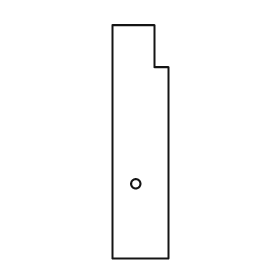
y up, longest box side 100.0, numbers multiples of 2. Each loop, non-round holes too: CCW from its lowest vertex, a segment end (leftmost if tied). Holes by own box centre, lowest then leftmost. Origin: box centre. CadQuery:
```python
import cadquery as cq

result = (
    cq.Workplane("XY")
    .moveTo(-12.0, -50.0)
    .lineTo(12.0, -50.0)
    .lineTo(12.0, 32.0)
    .lineTo(6.0, 32.0)
    .lineTo(6.0, 50.0)
    .lineTo(-12.0, 50.0)
    .close()
    .moveTo(-2.0, -18.0)
    .circle(2.0)
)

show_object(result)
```